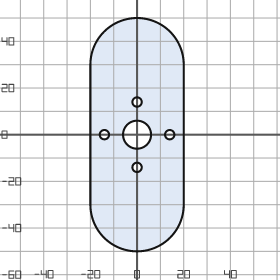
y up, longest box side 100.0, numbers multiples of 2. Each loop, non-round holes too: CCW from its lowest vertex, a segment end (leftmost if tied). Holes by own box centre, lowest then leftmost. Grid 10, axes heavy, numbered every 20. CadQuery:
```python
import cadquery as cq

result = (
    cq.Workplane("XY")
    .moveTo(-20.0, -30.0)
    .threePointArc((0.0, -50.0), (20.0, -30.0))
    .lineTo(20.0, 30.0)
    .threePointArc((0.0, 50.0), (-20.0, 30.0))
    .close()
    .moveTo(0.0, -14.0)
    .circle(2.0)
    .moveTo(-14.0, 0.0)
    .circle(2.0)
    .moveTo(0.0, 0.0)
    .circle(6.0)
    .moveTo(14.0, 0.0)
    .circle(2.0)
    .moveTo(0.0, 14.0)
    .circle(2.0)
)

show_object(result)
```